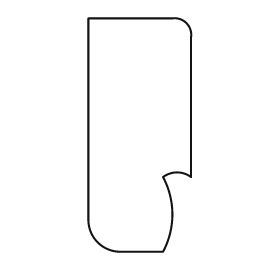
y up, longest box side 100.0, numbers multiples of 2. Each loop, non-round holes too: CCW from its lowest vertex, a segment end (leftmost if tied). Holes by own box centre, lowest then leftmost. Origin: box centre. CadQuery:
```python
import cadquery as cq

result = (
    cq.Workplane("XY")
    .moveTo(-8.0, -50.0)
    .lineTo(10.0, -50.0)
    .threePointArc((14.0, -34.0), (10.0, -18.0))
    .threePointArc((16.0, -16.0), (22.0, -18.0))
    .lineTo(22.0, 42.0)
    .threePointArc((20.0, 48.0), (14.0, 50.0))
    .lineTo(-22.0, 50.0)
    .lineTo(-22.0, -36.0)
    .threePointArc((-18.0, -46.0), (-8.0, -50.0))
    .close()
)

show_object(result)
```